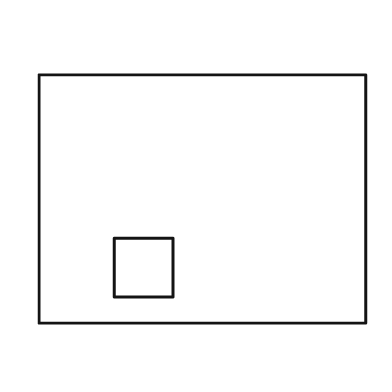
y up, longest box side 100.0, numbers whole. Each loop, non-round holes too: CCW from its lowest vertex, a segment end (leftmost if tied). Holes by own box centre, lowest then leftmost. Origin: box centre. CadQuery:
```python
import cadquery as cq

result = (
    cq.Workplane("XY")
    .moveTo(-50.0, -38.0)
    .lineTo(50.0, -38.0)
    .lineTo(50.0, 38.0)
    .lineTo(-50.0, 38.0)
    .close()
    .moveTo(-27.0, -30.0)
    .lineTo(-9.0, -30.0)
    .lineTo(-9.0, -12.0)
    .lineTo(-27.0, -12.0)
    .close()
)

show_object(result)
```